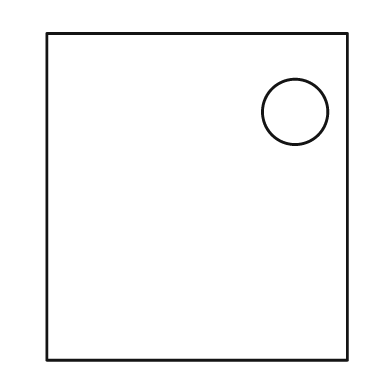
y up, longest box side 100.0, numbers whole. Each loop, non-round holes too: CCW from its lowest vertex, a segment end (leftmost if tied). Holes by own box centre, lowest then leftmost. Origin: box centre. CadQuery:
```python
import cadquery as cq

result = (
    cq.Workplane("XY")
    .moveTo(-46.0, -50.0)
    .lineTo(46.0, -50.0)
    .lineTo(46.0, 50.0)
    .lineTo(-46.0, 50.0)
    .close()
    .moveTo(30.0, 26.0)
    .circle(10.0)
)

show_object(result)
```